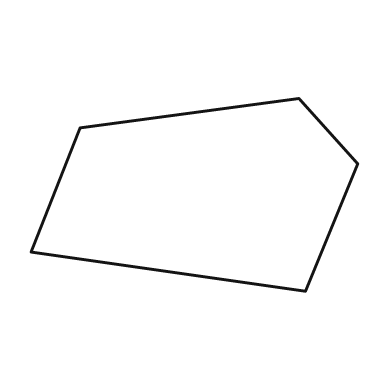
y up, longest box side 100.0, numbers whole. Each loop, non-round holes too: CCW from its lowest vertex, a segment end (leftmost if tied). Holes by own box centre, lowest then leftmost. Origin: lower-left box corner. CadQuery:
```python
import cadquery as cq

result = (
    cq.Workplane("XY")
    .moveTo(84.0, 0.0)
    .lineTo(100.0, 39.0)
    .lineTo(82.0, 59.0)
    .lineTo(15.0, 50.0)
    .lineTo(0.0, 12.0)
    .close()
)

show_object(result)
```